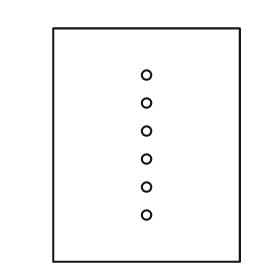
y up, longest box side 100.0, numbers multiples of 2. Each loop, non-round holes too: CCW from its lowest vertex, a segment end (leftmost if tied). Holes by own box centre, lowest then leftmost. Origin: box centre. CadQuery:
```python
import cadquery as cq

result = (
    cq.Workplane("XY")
    .moveTo(-40.0, -50.0)
    .lineTo(40.0, -50.0)
    .lineTo(40.0, 50.0)
    .lineTo(-40.0, 50.0)
    .close()
    .moveTo(0.0, -30.0)
    .circle(2.0)
    .moveTo(0.0, -18.0)
    .circle(2.0)
    .moveTo(0.0, -6.0)
    .circle(2.0)
    .moveTo(0.0, 6.0)
    .circle(2.0)
    .moveTo(0.0, 18.0)
    .circle(2.0)
    .moveTo(0.0, 30.0)
    .circle(2.0)
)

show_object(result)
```